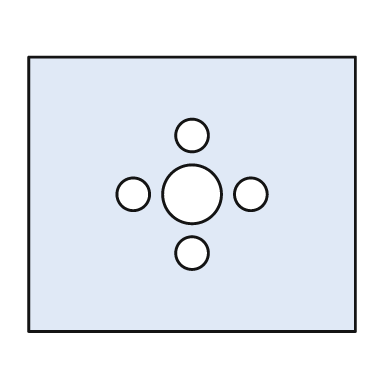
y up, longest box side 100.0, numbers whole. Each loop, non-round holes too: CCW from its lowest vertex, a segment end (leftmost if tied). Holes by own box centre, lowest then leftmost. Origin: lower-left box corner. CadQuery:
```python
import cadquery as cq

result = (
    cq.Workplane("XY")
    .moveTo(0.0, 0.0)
    .lineTo(100.0, 0.0)
    .lineTo(100.0, 84.0)
    .lineTo(0.0, 84.0)
    .close()
    .moveTo(50.0, 24.0)
    .circle(5.0)
    .moveTo(32.0, 42.0)
    .circle(5.0)
    .moveTo(50.0, 42.0)
    .circle(9.0)
    .moveTo(68.0, 42.0)
    .circle(5.0)
    .moveTo(50.0, 60.0)
    .circle(5.0)
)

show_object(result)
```